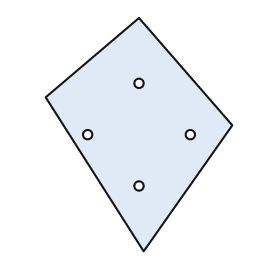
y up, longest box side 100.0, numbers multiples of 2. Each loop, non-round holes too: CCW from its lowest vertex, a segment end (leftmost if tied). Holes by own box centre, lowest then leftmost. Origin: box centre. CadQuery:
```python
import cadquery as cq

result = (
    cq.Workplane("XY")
    .moveTo(2.0, -50.0)
    .lineTo(40.0, 4.0)
    .lineTo(0.0, 50.0)
    .lineTo(-40.0, 16.0)
    .close()
    .moveTo(0.0, -22.0)
    .circle(2.0)
    .moveTo(-22.0, 0.0)
    .circle(2.0)
    .moveTo(22.0, 0.0)
    .circle(2.0)
    .moveTo(0.0, 22.0)
    .circle(2.0)
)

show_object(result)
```